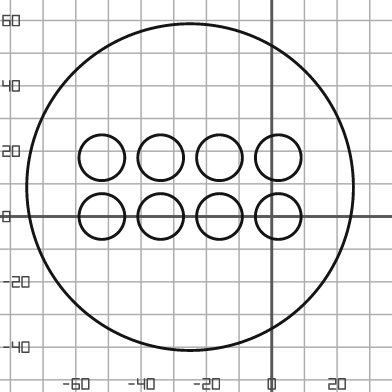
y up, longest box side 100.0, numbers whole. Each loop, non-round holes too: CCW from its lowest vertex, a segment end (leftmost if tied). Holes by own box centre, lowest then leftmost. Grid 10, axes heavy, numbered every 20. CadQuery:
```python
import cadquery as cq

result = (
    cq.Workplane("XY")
    .moveTo(-25.0, 9.0)
    .circle(50.0)
    .moveTo(-52.0, 0.0)
    .circle(7.0)
    .moveTo(-34.0, 0.0)
    .circle(7.0)
    .moveTo(-16.0, 0.0)
    .circle(7.0)
    .moveTo(2.0, 0.0)
    .circle(7.0)
    .moveTo(-52.0, 18.0)
    .circle(7.0)
    .moveTo(-34.0, 18.0)
    .circle(7.0)
    .moveTo(-16.0, 18.0)
    .circle(7.0)
    .moveTo(2.0, 18.0)
    .circle(7.0)
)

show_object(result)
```